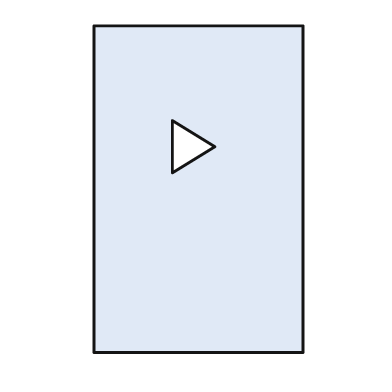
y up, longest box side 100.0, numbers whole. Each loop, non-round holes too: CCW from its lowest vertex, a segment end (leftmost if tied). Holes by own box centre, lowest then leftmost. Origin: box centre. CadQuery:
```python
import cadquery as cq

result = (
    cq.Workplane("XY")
    .moveTo(-32.0, -50.0)
    .lineTo(32.0, -50.0)
    .lineTo(32.0, 50.0)
    .lineTo(-32.0, 50.0)
    .close()
    .moveTo(-8.0, 5.0)
    .lineTo(5.0, 13.0)
    .lineTo(-8.0, 21.0)
    .close()
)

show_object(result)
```